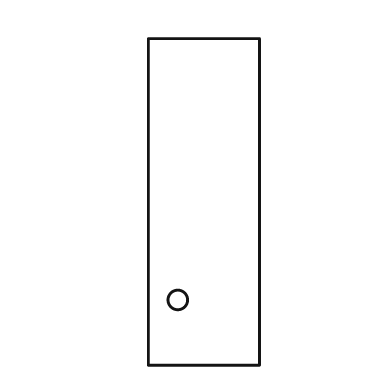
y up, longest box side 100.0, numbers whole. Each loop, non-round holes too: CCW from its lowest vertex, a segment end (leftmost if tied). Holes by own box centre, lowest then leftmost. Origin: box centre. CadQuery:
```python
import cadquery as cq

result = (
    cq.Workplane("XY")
    .moveTo(-17.0, -50.0)
    .lineTo(17.0, -50.0)
    .lineTo(17.0, 50.0)
    .lineTo(-17.0, 50.0)
    .close()
    .moveTo(-8.0, -30.0)
    .circle(3.0)
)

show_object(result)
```